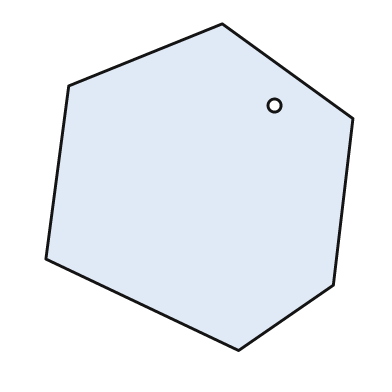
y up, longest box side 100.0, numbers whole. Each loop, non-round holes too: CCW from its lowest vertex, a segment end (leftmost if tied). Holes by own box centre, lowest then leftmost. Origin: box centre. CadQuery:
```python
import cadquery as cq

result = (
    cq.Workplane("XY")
    .moveTo(12.0, -50.0)
    .lineTo(41.0, -30.0)
    .lineTo(47.0, 21.0)
    .lineTo(7.0, 50.0)
    .lineTo(-40.0, 31.0)
    .lineTo(-47.0, -22.0)
    .close()
    .moveTo(23.0, 25.0)
    .circle(2.0)
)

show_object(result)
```